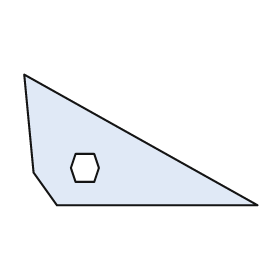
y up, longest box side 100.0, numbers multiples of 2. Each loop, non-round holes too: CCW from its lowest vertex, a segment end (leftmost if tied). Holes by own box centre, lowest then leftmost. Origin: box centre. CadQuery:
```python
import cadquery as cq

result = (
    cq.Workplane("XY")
    .moveTo(-36.0, -28.0)
    .lineTo(50.0, -28.0)
    .lineTo(-50.0, 28.0)
    .lineTo(-46.0, -14.0)
    .close()
    .moveTo(-28.0, -18.0)
    .lineTo(-20.0, -18.0)
    .lineTo(-18.0, -12.0)
    .lineTo(-20.0, -6.0)
    .lineTo(-28.0, -6.0)
    .lineTo(-30.0, -12.0)
    .close()
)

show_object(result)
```